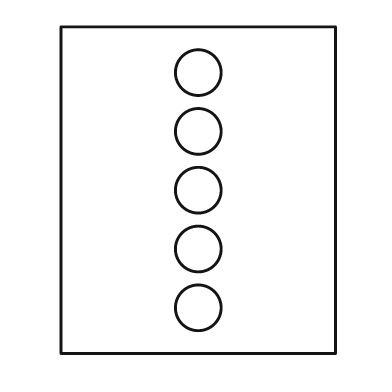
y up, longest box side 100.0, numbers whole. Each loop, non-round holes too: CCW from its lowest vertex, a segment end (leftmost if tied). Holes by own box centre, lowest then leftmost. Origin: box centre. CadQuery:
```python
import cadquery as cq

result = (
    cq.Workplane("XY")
    .moveTo(-42.0, -50.0)
    .lineTo(42.0, -50.0)
    .lineTo(42.0, 50.0)
    .lineTo(-42.0, 50.0)
    .close()
    .moveTo(0.0, -36.0)
    .circle(7.0)
    .moveTo(0.0, -18.0)
    .circle(7.0)
    .moveTo(0.0, 0.0)
    .circle(7.0)
    .moveTo(0.0, 18.0)
    .circle(7.0)
    .moveTo(0.0, 36.0)
    .circle(7.0)
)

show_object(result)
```